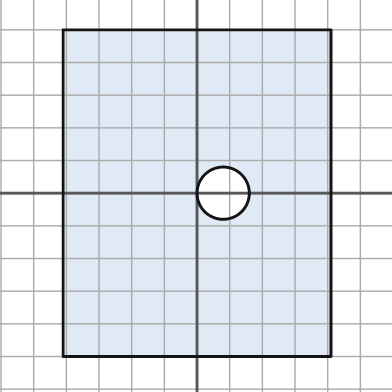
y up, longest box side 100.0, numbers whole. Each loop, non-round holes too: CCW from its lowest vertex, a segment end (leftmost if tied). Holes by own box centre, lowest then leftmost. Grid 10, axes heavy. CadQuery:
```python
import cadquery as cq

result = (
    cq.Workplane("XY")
    .moveTo(-41.0, -50.0)
    .lineTo(41.0, -50.0)
    .lineTo(41.0, 50.0)
    .lineTo(-41.0, 50.0)
    .close()
    .moveTo(8.0, 0.0)
    .circle(8.0)
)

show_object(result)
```